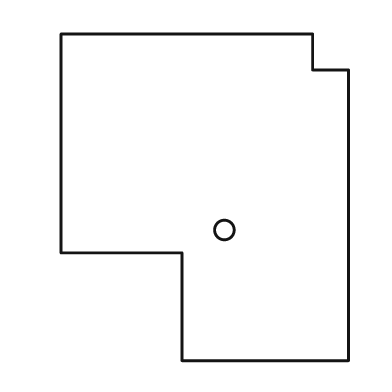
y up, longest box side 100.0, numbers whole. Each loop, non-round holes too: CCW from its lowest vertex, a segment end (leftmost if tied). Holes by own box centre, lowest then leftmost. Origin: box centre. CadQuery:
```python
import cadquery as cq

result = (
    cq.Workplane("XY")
    .moveTo(-7.0, -50.0)
    .lineTo(44.0, -50.0)
    .lineTo(44.0, 39.0)
    .lineTo(33.0, 39.0)
    .lineTo(33.0, 50.0)
    .lineTo(-44.0, 50.0)
    .lineTo(-44.0, -17.0)
    .lineTo(-7.0, -17.0)
    .close()
    .moveTo(6.0, -10.0)
    .circle(3.0)
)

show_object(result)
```